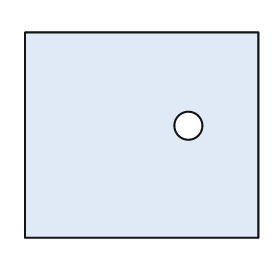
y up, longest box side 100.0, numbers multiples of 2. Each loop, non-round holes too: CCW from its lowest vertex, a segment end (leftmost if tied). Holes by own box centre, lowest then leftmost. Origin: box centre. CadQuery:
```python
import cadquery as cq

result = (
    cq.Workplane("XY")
    .moveTo(-50.0, -44.0)
    .lineTo(50.0, -44.0)
    .lineTo(50.0, 44.0)
    .lineTo(-50.0, 44.0)
    .close()
    .moveTo(20.0, 4.0)
    .circle(6.0)
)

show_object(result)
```